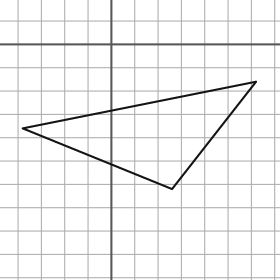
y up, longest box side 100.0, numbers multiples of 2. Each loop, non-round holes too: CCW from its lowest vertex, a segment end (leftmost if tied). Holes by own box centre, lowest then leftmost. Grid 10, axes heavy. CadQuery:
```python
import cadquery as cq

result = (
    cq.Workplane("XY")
    .moveTo(26.0, -62.0)
    .lineTo(62.0, -16.0)
    .lineTo(-38.0, -36.0)
    .close()
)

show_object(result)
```